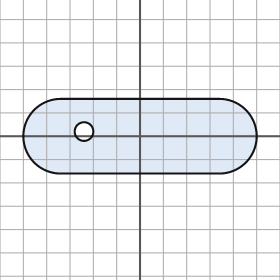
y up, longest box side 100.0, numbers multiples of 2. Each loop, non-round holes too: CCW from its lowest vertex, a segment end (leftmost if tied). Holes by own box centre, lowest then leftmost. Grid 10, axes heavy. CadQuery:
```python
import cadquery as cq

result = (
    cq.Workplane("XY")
    .moveTo(-34.0, -16.0)
    .lineTo(34.0, -16.0)
    .threePointArc((50.0, 0.0), (34.0, 16.0))
    .lineTo(-34.0, 16.0)
    .threePointArc((-50.0, 0.0), (-34.0, -16.0))
    .close()
    .moveTo(-24.0, 2.0)
    .circle(4.0)
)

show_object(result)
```